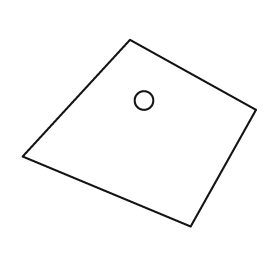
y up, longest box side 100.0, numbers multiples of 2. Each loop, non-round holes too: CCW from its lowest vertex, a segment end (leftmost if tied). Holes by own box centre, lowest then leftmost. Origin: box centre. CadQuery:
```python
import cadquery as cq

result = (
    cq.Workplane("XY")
    .moveTo(22.0, -40.0)
    .lineTo(50.0, 10.0)
    .lineTo(-4.0, 40.0)
    .lineTo(-50.0, -10.0)
    .close()
    .moveTo(2.0, 14.0)
    .circle(4.0)
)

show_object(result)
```